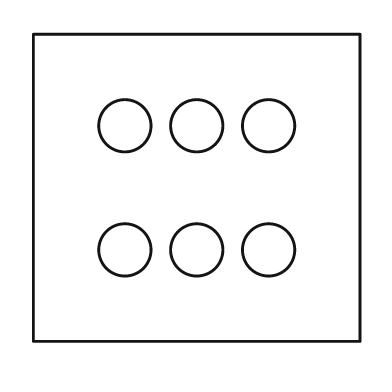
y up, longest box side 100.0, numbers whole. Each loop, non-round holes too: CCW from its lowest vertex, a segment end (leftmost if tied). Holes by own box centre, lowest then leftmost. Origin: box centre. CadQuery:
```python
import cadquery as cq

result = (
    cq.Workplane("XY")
    .moveTo(-50.0, -47.0)
    .lineTo(50.0, -47.0)
    .lineTo(50.0, 47.0)
    .lineTo(-50.0, 47.0)
    .close()
    .moveTo(-22.0, -19.0)
    .circle(8.0)
    .moveTo(0.0, -19.0)
    .circle(8.0)
    .moveTo(22.0, -19.0)
    .circle(8.0)
    .moveTo(-22.0, 19.0)
    .circle(8.0)
    .moveTo(0.0, 19.0)
    .circle(8.0)
    .moveTo(22.0, 19.0)
    .circle(8.0)
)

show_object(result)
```